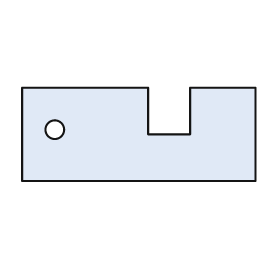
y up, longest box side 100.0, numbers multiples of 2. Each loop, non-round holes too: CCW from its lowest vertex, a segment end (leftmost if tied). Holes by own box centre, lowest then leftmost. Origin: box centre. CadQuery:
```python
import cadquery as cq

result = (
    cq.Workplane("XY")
    .moveTo(-50.0, -20.0)
    .lineTo(50.0, -20.0)
    .lineTo(50.0, 20.0)
    .lineTo(22.0, 20.0)
    .lineTo(22.0, 0.0)
    .lineTo(4.0, 0.0)
    .lineTo(4.0, 20.0)
    .lineTo(-50.0, 20.0)
    .close()
    .moveTo(-36.0, 2.0)
    .circle(4.0)
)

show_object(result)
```